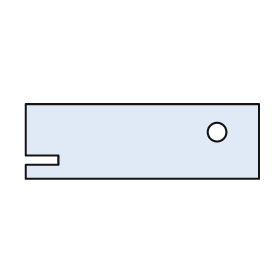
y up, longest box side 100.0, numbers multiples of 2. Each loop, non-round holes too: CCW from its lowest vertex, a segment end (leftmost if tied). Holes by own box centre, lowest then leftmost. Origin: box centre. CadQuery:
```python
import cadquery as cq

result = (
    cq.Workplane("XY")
    .moveTo(-50.0, -16.0)
    .lineTo(50.0, -16.0)
    .lineTo(50.0, 16.0)
    .lineTo(-50.0, 16.0)
    .lineTo(-50.0, -6.0)
    .lineTo(-36.0, -6.0)
    .lineTo(-36.0, -10.0)
    .lineTo(-50.0, -10.0)
    .close()
    .moveTo(32.0, 4.0)
    .circle(4.0)
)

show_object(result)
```